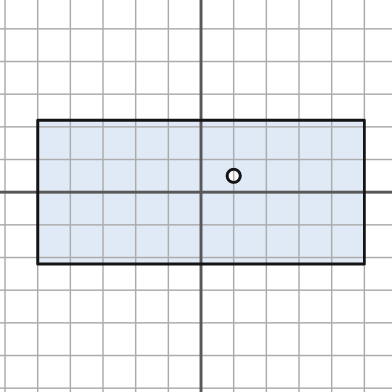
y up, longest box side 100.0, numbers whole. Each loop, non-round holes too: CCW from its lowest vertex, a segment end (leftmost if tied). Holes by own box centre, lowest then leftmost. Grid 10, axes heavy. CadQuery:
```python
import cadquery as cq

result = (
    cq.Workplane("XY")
    .moveTo(-50.0, -22.0)
    .lineTo(50.0, -22.0)
    .lineTo(50.0, 22.0)
    .lineTo(-50.0, 22.0)
    .close()
    .moveTo(10.0, 5.0)
    .circle(2.0)
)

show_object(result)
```